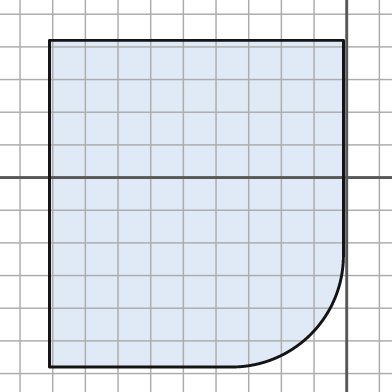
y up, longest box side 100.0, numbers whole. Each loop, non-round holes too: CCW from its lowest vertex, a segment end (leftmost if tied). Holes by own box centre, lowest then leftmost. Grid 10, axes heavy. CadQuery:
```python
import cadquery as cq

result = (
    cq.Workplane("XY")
    .moveTo(-91.0, -58.0)
    .lineTo(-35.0, -58.0)
    .threePointArc((-11.0, -48.0), (-1.0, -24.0))
    .lineTo(-1.0, 42.0)
    .lineTo(-91.0, 42.0)
    .close()
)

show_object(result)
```